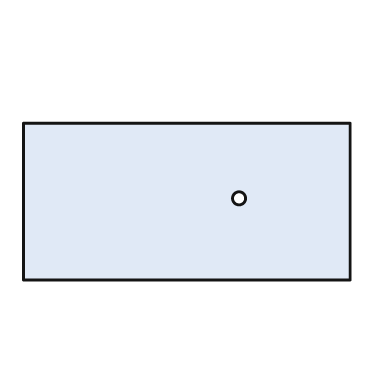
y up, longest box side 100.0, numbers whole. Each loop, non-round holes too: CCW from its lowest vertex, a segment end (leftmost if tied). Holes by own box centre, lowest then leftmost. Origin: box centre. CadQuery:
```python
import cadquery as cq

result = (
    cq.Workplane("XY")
    .moveTo(-50.0, -24.0)
    .lineTo(50.0, -24.0)
    .lineTo(50.0, 24.0)
    .lineTo(-50.0, 24.0)
    .close()
    .moveTo(16.0, 1.0)
    .circle(2.0)
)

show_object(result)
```